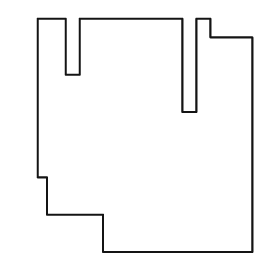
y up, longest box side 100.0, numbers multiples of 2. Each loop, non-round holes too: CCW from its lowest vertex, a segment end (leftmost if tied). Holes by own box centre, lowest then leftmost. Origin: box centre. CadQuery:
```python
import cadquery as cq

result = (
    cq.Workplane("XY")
    .moveTo(-18.0, -50.0)
    .lineTo(46.0, -50.0)
    .lineTo(46.0, 42.0)
    .lineTo(28.0, 42.0)
    .lineTo(28.0, 50.0)
    .lineTo(22.0, 50.0)
    .lineTo(22.0, 10.0)
    .lineTo(16.0, 10.0)
    .lineTo(16.0, 50.0)
    .lineTo(-28.0, 50.0)
    .lineTo(-28.0, 26.0)
    .lineTo(-34.0, 26.0)
    .lineTo(-34.0, 50.0)
    .lineTo(-46.0, 50.0)
    .lineTo(-46.0, -18.0)
    .lineTo(-42.0, -18.0)
    .lineTo(-42.0, -34.0)
    .lineTo(-18.0, -34.0)
    .close()
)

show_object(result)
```